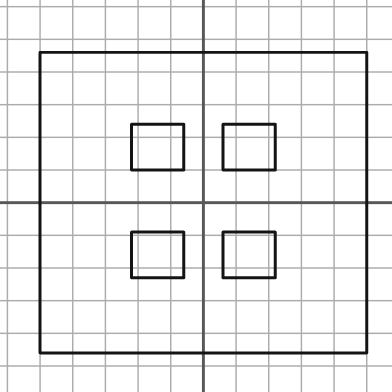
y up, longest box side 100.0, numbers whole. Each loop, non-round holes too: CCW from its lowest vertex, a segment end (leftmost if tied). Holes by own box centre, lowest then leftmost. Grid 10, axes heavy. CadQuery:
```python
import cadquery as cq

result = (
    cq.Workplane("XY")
    .moveTo(-50.0, -46.0)
    .lineTo(50.0, -46.0)
    .lineTo(50.0, 46.0)
    .lineTo(-50.0, 46.0)
    .close()
    .moveTo(-22.0, -23.0)
    .lineTo(-6.0, -23.0)
    .lineTo(-6.0, -9.0)
    .lineTo(-22.0, -9.0)
    .close()
    .moveTo(6.0, -23.0)
    .lineTo(22.0, -23.0)
    .lineTo(22.0, -9.0)
    .lineTo(6.0, -9.0)
    .close()
    .moveTo(-22.0, 10.0)
    .lineTo(-6.0, 10.0)
    .lineTo(-6.0, 24.0)
    .lineTo(-22.0, 24.0)
    .close()
    .moveTo(6.0, 10.0)
    .lineTo(22.0, 10.0)
    .lineTo(22.0, 24.0)
    .lineTo(6.0, 24.0)
    .close()
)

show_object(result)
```